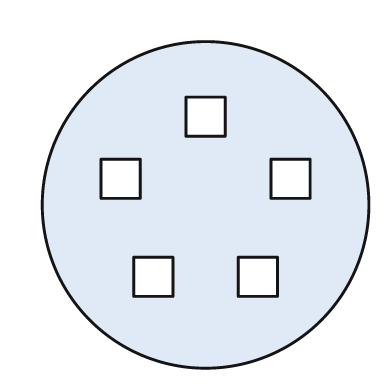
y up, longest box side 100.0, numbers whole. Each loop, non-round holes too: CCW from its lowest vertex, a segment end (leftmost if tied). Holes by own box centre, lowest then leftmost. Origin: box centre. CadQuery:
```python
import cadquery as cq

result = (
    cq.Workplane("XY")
    .moveTo(0.0, 0.0)
    .circle(50.0)
    .moveTo(-22.0, -28.0)
    .lineTo(-10.0, -28.0)
    .lineTo(-10.0, -16.0)
    .lineTo(-22.0, -16.0)
    .close()
    .moveTo(10.0, -28.0)
    .lineTo(22.0, -28.0)
    .lineTo(22.0, -16.0)
    .lineTo(10.0, -16.0)
    .close()
    .moveTo(-32.0, 2.0)
    .lineTo(-20.0, 2.0)
    .lineTo(-20.0, 14.0)
    .lineTo(-32.0, 14.0)
    .close()
    .moveTo(20.0, 2.0)
    .lineTo(32.0, 2.0)
    .lineTo(32.0, 14.0)
    .lineTo(20.0, 14.0)
    .close()
    .moveTo(-6.0, 21.0)
    .lineTo(6.0, 21.0)
    .lineTo(6.0, 33.0)
    .lineTo(-6.0, 33.0)
    .close()
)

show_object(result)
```